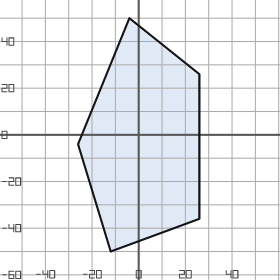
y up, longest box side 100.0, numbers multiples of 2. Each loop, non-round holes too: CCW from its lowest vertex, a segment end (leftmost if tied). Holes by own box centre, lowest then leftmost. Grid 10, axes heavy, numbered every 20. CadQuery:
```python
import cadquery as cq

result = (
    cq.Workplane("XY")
    .moveTo(-12.0, -50.0)
    .lineTo(26.0, -36.0)
    .lineTo(26.0, 26.0)
    .lineTo(-4.0, 50.0)
    .lineTo(-26.0, -4.0)
    .close()
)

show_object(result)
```